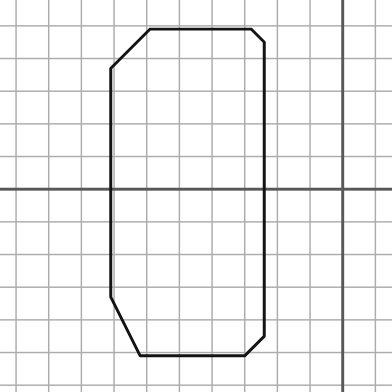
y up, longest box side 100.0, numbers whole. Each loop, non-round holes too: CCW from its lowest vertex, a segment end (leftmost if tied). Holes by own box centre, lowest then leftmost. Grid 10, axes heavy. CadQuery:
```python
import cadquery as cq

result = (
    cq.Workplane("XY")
    .moveTo(-62.0, -51.0)
    .lineTo(-30.0, -51.0)
    .lineTo(-24.0, -45.0)
    .lineTo(-24.0, 45.0)
    .lineTo(-28.0, 49.0)
    .lineTo(-59.0, 49.0)
    .lineTo(-71.0, 37.0)
    .lineTo(-71.0, -33.0)
    .close()
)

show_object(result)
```